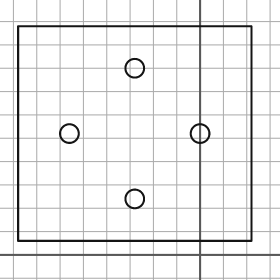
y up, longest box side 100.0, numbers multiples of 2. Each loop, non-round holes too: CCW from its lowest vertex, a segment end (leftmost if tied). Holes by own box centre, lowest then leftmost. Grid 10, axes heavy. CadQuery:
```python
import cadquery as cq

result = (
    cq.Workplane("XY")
    .moveTo(-78.0, 6.0)
    .lineTo(22.0, 6.0)
    .lineTo(22.0, 98.0)
    .lineTo(-78.0, 98.0)
    .close()
    .moveTo(-28.0, 24.0)
    .circle(4.0)
    .moveTo(-56.0, 52.0)
    .circle(4.0)
    .moveTo(0.0, 52.0)
    .circle(4.0)
    .moveTo(-28.0, 80.0)
    .circle(4.0)
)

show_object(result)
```